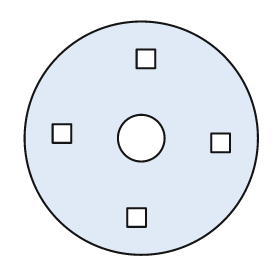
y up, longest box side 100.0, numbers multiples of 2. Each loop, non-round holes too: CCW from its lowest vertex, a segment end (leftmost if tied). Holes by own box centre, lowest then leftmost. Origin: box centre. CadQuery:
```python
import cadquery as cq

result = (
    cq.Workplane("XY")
    .moveTo(0.0, 0.0)
    .circle(50.0)
    .moveTo(-6.0, -38.0)
    .lineTo(2.0, -38.0)
    .lineTo(2.0, -30.0)
    .lineTo(-6.0, -30.0)
    .close()
    .moveTo(30.0, -6.0)
    .lineTo(38.0, -6.0)
    .lineTo(38.0, 2.0)
    .lineTo(30.0, 2.0)
    .close()
    .moveTo(0.0, 0.0)
    .circle(10.0)
    .moveTo(-38.0, -2.0)
    .lineTo(-30.0, -2.0)
    .lineTo(-30.0, 6.0)
    .lineTo(-38.0, 6.0)
    .close()
    .moveTo(-2.0, 30.0)
    .lineTo(6.0, 30.0)
    .lineTo(6.0, 38.0)
    .lineTo(-2.0, 38.0)
    .close()
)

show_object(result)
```